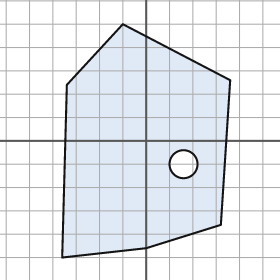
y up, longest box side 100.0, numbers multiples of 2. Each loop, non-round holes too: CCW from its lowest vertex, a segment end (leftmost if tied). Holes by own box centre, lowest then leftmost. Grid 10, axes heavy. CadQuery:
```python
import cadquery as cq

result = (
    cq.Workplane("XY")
    .moveTo(-36.0, -50.0)
    .lineTo(0.0, -46.0)
    .lineTo(32.0, -36.0)
    .lineTo(36.0, 26.0)
    .lineTo(-10.0, 50.0)
    .lineTo(-34.0, 24.0)
    .close()
    .moveTo(16.0, -10.0)
    .circle(6.0)
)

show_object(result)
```